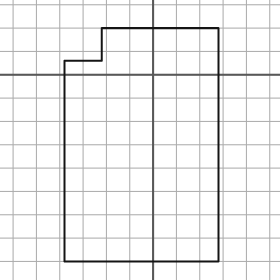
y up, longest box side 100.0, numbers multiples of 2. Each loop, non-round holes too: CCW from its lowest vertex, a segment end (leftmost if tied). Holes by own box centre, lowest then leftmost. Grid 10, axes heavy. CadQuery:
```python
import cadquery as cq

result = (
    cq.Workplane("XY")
    .moveTo(-38.0, -80.0)
    .lineTo(28.0, -80.0)
    .lineTo(28.0, 20.0)
    .lineTo(-22.0, 20.0)
    .lineTo(-22.0, 6.0)
    .lineTo(-38.0, 6.0)
    .close()
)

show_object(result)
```